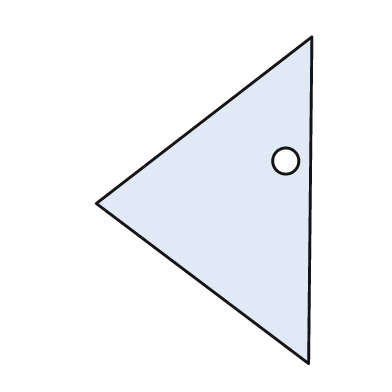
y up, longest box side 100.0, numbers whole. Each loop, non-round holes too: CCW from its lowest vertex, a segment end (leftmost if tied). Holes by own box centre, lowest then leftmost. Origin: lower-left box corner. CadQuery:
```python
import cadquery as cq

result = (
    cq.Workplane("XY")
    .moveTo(65.0, 0.0)
    .lineTo(66.0, 100.0)
    .lineTo(0.0, 49.0)
    .close()
    .moveTo(58.0, 62.0)
    .circle(4.0)
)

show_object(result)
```